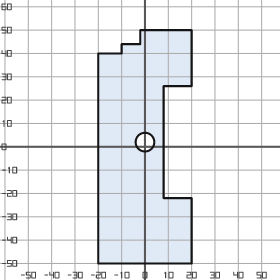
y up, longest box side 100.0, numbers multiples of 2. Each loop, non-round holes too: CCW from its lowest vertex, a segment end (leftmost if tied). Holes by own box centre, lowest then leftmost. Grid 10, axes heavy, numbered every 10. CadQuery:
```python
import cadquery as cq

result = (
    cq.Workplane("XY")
    .moveTo(-20.0, -50.0)
    .lineTo(20.0, -50.0)
    .lineTo(20.0, -22.0)
    .lineTo(8.0, -22.0)
    .lineTo(8.0, 26.0)
    .lineTo(20.0, 26.0)
    .lineTo(20.0, 50.0)
    .lineTo(-2.0, 50.0)
    .lineTo(-2.0, 44.0)
    .lineTo(-10.0, 44.0)
    .lineTo(-10.0, 40.0)
    .lineTo(-20.0, 40.0)
    .close()
    .moveTo(0.0, 2.0)
    .circle(4.0)
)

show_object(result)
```